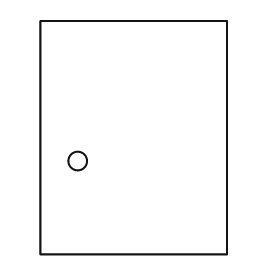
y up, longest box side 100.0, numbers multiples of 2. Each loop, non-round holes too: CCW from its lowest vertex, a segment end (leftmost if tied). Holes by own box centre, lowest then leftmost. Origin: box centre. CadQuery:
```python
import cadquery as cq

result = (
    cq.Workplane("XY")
    .moveTo(-40.0, -50.0)
    .lineTo(40.0, -50.0)
    .lineTo(40.0, 50.0)
    .lineTo(-40.0, 50.0)
    .close()
    .moveTo(-24.0, -10.0)
    .circle(4.0)
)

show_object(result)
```